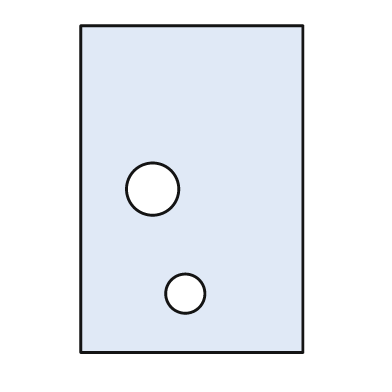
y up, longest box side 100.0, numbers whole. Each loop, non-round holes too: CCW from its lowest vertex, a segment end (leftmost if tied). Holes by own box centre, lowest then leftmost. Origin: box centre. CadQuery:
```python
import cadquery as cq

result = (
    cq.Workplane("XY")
    .moveTo(-34.0, -50.0)
    .lineTo(34.0, -50.0)
    .lineTo(34.0, 50.0)
    .lineTo(-34.0, 50.0)
    .close()
    .moveTo(-2.0, -32.0)
    .circle(6.0)
    .moveTo(-12.0, 0.0)
    .circle(8.0)
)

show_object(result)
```